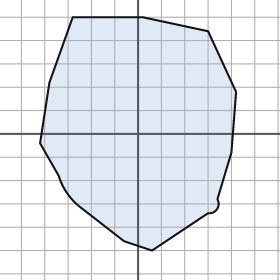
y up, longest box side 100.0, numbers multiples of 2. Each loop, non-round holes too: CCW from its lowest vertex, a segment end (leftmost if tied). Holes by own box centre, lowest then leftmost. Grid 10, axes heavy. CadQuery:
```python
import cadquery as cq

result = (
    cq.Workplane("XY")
    .moveTo(6.0, -50.0)
    .lineTo(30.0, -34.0)
    .threePointArc((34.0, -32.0), (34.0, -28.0))
    .lineTo(40.0, -8.0)
    .lineTo(42.0, 18.0)
    .lineTo(30.0, 44.0)
    .lineTo(2.0, 50.0)
    .lineTo(-28.0, 50.0)
    .lineTo(-38.0, 22.0)
    .lineTo(-42.0, -4.0)
    .lineTo(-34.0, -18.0)
    .threePointArc((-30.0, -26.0), (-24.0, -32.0))
    .lineTo(-6.0, -46.0)
    .close()
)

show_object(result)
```